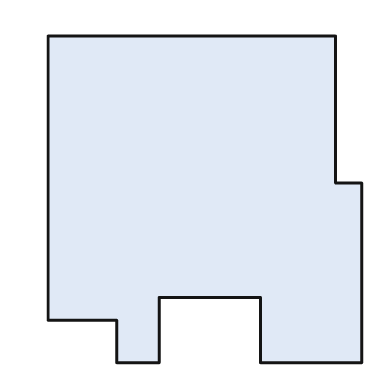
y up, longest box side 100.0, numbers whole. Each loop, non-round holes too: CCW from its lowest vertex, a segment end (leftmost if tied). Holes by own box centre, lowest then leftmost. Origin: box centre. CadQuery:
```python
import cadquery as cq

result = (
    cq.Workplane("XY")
    .moveTo(-27.0, -50.0)
    .lineTo(-14.0, -50.0)
    .lineTo(-14.0, -30.0)
    .lineTo(17.0, -30.0)
    .lineTo(17.0, -50.0)
    .lineTo(48.0, -50.0)
    .lineTo(48.0, 5.0)
    .lineTo(40.0, 5.0)
    .lineTo(40.0, 50.0)
    .lineTo(-48.0, 50.0)
    .lineTo(-48.0, -37.0)
    .lineTo(-27.0, -37.0)
    .close()
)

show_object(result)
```